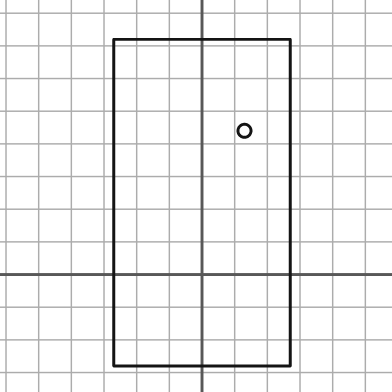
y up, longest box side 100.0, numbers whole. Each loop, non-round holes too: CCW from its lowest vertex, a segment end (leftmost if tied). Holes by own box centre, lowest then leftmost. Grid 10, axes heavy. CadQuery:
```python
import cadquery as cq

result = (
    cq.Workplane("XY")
    .moveTo(-27.0, -28.0)
    .lineTo(27.0, -28.0)
    .lineTo(27.0, 72.0)
    .lineTo(-27.0, 72.0)
    .close()
    .moveTo(13.0, 44.0)
    .circle(2.0)
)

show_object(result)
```